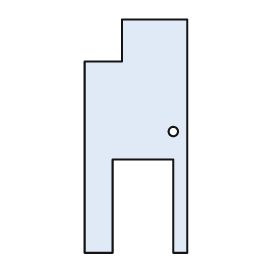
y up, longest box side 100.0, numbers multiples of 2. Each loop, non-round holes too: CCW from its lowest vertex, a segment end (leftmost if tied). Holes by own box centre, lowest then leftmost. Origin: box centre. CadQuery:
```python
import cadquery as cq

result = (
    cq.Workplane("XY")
    .moveTo(-22.0, -50.0)
    .lineTo(-10.0, -50.0)
    .lineTo(-10.0, -10.0)
    .lineTo(16.0, -10.0)
    .lineTo(16.0, -50.0)
    .lineTo(22.0, -50.0)
    .lineTo(22.0, 50.0)
    .lineTo(-6.0, 50.0)
    .lineTo(-6.0, 32.0)
    .lineTo(-22.0, 32.0)
    .close()
    .moveTo(16.0, 2.0)
    .circle(2.0)
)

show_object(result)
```